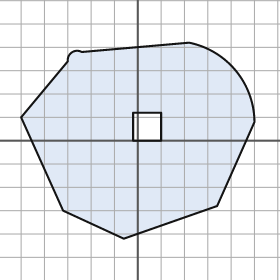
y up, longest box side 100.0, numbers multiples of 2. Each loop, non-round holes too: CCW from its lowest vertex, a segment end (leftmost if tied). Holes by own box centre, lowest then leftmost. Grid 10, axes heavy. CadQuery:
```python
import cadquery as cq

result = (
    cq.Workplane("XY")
    .moveTo(-6.0, -42.0)
    .lineTo(34.0, -28.0)
    .lineTo(50.0, 8.0)
    .threePointArc((42.0, 30.0), (22.0, 42.0))
    .lineTo(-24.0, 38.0)
    .threePointArc((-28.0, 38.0), (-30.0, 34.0))
    .lineTo(-50.0, 10.0)
    .lineTo(-32.0, -30.0)
    .close()
    .moveTo(-2.0, 0.0)
    .lineTo(10.0, 0.0)
    .lineTo(10.0, 12.0)
    .lineTo(-2.0, 12.0)
    .close()
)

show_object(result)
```